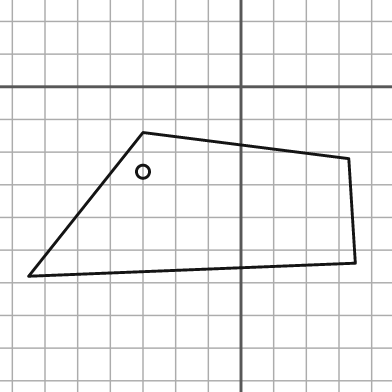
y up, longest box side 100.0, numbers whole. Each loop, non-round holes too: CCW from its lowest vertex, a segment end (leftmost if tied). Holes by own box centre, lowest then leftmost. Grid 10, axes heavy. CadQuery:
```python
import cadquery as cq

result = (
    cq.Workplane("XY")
    .moveTo(-65.0, -58.0)
    .lineTo(35.0, -54.0)
    .lineTo(33.0, -22.0)
    .lineTo(-30.0, -14.0)
    .close()
    .moveTo(-30.0, -26.0)
    .circle(2.0)
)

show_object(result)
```